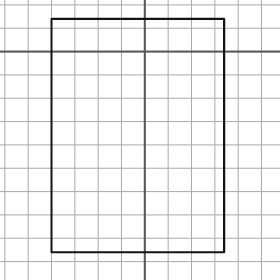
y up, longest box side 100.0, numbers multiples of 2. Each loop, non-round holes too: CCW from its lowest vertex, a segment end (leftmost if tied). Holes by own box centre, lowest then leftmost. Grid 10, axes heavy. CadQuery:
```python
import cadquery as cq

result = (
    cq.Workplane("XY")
    .moveTo(-40.0, -86.0)
    .lineTo(34.0, -86.0)
    .lineTo(34.0, 14.0)
    .lineTo(-40.0, 14.0)
    .close()
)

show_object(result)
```